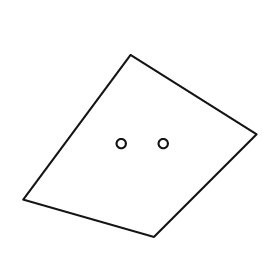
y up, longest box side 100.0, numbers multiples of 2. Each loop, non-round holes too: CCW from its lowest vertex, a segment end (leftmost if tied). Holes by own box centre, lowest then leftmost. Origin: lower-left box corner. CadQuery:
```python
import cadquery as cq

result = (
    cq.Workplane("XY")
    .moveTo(56.0, 0.0)
    .lineTo(100.0, 44.0)
    .lineTo(46.0, 78.0)
    .lineTo(0.0, 16.0)
    .close()
    .moveTo(42.0, 40.0)
    .circle(2.0)
    .moveTo(60.0, 40.0)
    .circle(2.0)
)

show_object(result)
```